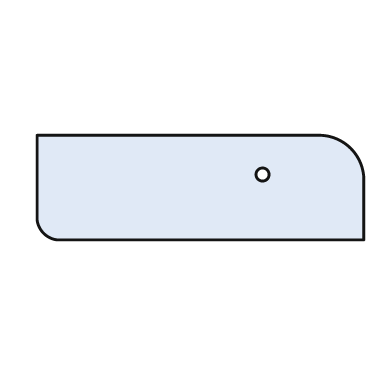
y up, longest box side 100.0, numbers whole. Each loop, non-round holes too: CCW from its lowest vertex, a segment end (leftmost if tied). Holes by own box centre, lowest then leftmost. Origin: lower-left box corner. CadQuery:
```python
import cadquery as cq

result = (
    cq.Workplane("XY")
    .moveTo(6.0, 0.0)
    .lineTo(100.0, 0.0)
    .lineTo(100.0, 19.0)
    .threePointArc((96.0, 28.0), (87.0, 32.0))
    .lineTo(0.0, 32.0)
    .lineTo(0.0, 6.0)
    .threePointArc((2.0, 2.0), (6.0, 0.0))
    .close()
    .moveTo(69.0, 20.0)
    .circle(2.0)
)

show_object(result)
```